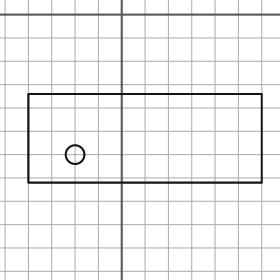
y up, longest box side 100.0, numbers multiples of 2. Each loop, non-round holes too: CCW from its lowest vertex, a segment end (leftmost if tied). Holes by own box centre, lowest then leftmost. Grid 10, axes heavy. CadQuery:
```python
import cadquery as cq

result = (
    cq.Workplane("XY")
    .moveTo(-40.0, -72.0)
    .lineTo(60.0, -72.0)
    .lineTo(60.0, -34.0)
    .lineTo(-40.0, -34.0)
    .close()
    .moveTo(-20.0, -60.0)
    .circle(4.0)
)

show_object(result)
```